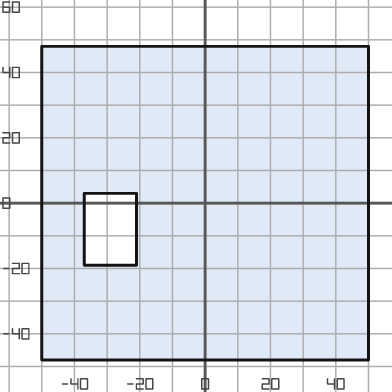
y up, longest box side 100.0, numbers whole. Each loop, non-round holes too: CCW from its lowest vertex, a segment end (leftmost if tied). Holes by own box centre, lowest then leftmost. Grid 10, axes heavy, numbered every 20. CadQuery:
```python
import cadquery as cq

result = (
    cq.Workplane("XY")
    .moveTo(-50.0, -48.0)
    .lineTo(50.0, -48.0)
    .lineTo(50.0, 48.0)
    .lineTo(-50.0, 48.0)
    .close()
    .moveTo(-37.0, -19.0)
    .lineTo(-21.0, -19.0)
    .lineTo(-21.0, 3.0)
    .lineTo(-37.0, 3.0)
    .close()
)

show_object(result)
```